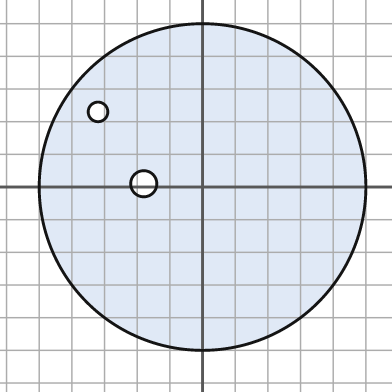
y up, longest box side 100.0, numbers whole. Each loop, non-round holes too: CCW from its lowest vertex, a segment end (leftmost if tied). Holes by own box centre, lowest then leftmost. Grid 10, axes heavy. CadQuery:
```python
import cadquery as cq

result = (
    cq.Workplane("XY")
    .moveTo(0.0, 0.0)
    .circle(50.0)
    .moveTo(-18.0, 1.0)
    .circle(4.0)
    .moveTo(-32.0, 23.0)
    .circle(3.0)
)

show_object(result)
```